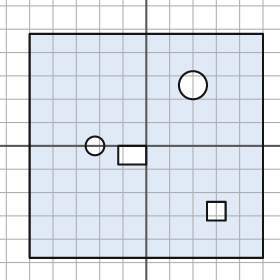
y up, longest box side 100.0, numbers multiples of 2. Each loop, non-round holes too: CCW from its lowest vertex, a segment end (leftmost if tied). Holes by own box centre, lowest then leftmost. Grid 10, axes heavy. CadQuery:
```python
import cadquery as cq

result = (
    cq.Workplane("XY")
    .moveTo(-50.0, -48.0)
    .lineTo(50.0, -48.0)
    .lineTo(50.0, 48.0)
    .lineTo(-50.0, 48.0)
    .close()
    .moveTo(26.0, -32.0)
    .lineTo(34.0, -32.0)
    .lineTo(34.0, -24.0)
    .lineTo(26.0, -24.0)
    .close()
    .moveTo(-12.0, -8.0)
    .lineTo(0.0, -8.0)
    .lineTo(0.0, 0.0)
    .lineTo(-12.0, 0.0)
    .close()
    .moveTo(-22.0, 0.0)
    .circle(4.0)
    .moveTo(20.0, 26.0)
    .circle(6.0)
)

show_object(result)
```